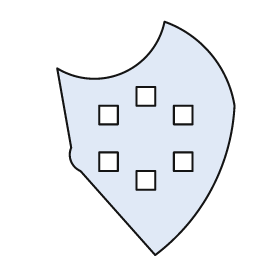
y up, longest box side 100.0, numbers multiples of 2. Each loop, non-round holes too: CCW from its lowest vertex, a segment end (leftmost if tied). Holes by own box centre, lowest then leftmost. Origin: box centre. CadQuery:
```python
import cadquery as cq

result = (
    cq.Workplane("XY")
    .moveTo(4.0, -50.0)
    .threePointArc((28.0, -22.0), (38.0, 14.0))
    .threePointArc((28.0, 36.0), (8.0, 50.0))
    .threePointArc((-10.0, 28.0), (-38.0, 30.0))
    .lineTo(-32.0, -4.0)
    .threePointArc((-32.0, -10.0), (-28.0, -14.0))
    .close()
    .moveTo(-4.0, -22.0)
    .lineTo(4.0, -22.0)
    .lineTo(4.0, -14.0)
    .lineTo(-4.0, -14.0)
    .close()
    .moveTo(-20.0, -14.0)
    .lineTo(-12.0, -14.0)
    .lineTo(-12.0, -6.0)
    .lineTo(-20.0, -6.0)
    .close()
    .moveTo(12.0, -14.0)
    .lineTo(20.0, -14.0)
    .lineTo(20.0, -6.0)
    .lineTo(12.0, -6.0)
    .close()
    .moveTo(-20.0, 6.0)
    .lineTo(-12.0, 6.0)
    .lineTo(-12.0, 14.0)
    .lineTo(-20.0, 14.0)
    .close()
    .moveTo(12.0, 6.0)
    .lineTo(20.0, 6.0)
    .lineTo(20.0, 14.0)
    .lineTo(12.0, 14.0)
    .close()
    .moveTo(-4.0, 14.0)
    .lineTo(4.0, 14.0)
    .lineTo(4.0, 22.0)
    .lineTo(-4.0, 22.0)
    .close()
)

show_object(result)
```